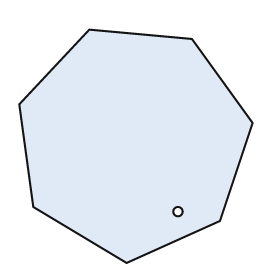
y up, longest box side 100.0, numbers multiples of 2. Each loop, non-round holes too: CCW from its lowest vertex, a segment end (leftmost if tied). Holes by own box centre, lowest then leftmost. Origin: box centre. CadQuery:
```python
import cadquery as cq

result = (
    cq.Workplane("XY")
    .moveTo(-4.0, -50.0)
    .lineTo(36.0, -32.0)
    .lineTo(50.0, 10.0)
    .lineTo(24.0, 46.0)
    .lineTo(-20.0, 50.0)
    .lineTo(-50.0, 18.0)
    .lineTo(-44.0, -26.0)
    .close()
    .moveTo(18.0, -28.0)
    .circle(2.0)
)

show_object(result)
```